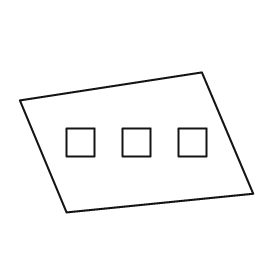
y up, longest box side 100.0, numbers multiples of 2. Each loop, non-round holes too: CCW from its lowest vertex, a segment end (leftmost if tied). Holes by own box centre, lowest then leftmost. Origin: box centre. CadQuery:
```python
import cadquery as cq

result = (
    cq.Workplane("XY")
    .moveTo(-30.0, -30.0)
    .lineTo(50.0, -22.0)
    .lineTo(28.0, 30.0)
    .lineTo(-50.0, 18.0)
    .close()
    .moveTo(-30.0, -6.0)
    .lineTo(-18.0, -6.0)
    .lineTo(-18.0, 6.0)
    .lineTo(-30.0, 6.0)
    .close()
    .moveTo(-6.0, -6.0)
    .lineTo(6.0, -6.0)
    .lineTo(6.0, 6.0)
    .lineTo(-6.0, 6.0)
    .close()
    .moveTo(18.0, -6.0)
    .lineTo(30.0, -6.0)
    .lineTo(30.0, 6.0)
    .lineTo(18.0, 6.0)
    .close()
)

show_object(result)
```